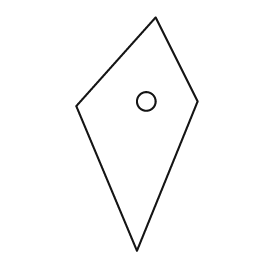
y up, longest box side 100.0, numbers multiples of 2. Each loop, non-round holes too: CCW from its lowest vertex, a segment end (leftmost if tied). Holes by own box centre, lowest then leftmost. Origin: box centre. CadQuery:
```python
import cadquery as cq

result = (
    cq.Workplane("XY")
    .moveTo(0.0, -50.0)
    .lineTo(26.0, 14.0)
    .lineTo(8.0, 50.0)
    .lineTo(-26.0, 12.0)
    .close()
    .moveTo(4.0, 14.0)
    .circle(4.0)
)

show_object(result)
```